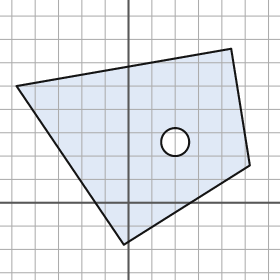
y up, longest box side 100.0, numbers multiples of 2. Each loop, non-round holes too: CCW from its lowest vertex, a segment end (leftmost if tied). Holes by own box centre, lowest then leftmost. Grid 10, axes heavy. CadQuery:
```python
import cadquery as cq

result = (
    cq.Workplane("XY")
    .moveTo(-2.0, -18.0)
    .lineTo(52.0, 16.0)
    .lineTo(44.0, 66.0)
    .lineTo(-48.0, 50.0)
    .close()
    .moveTo(20.0, 26.0)
    .circle(6.0)
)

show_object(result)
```